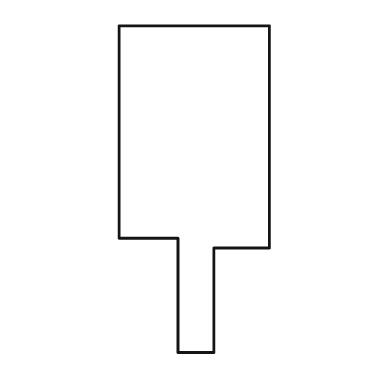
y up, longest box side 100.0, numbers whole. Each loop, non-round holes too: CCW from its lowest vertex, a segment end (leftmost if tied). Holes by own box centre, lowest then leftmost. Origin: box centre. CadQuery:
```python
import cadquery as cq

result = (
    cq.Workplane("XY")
    .moveTo(-5.0, -50.0)
    .lineTo(6.0, -50.0)
    .lineTo(6.0, -18.0)
    .lineTo(23.0, -18.0)
    .lineTo(23.0, 50.0)
    .lineTo(-23.0, 50.0)
    .lineTo(-23.0, -15.0)
    .lineTo(-5.0, -15.0)
    .close()
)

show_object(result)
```